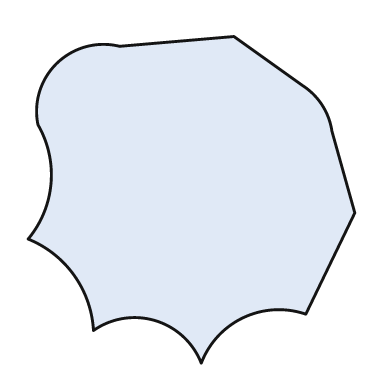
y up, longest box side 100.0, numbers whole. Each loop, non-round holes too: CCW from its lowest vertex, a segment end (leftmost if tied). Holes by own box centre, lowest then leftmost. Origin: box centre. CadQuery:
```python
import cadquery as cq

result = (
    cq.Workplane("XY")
    .moveTo(3.0, -50.0)
    .threePointArc((16.0, -36.0), (35.0, -35.0))
    .lineTo(50.0, -4.0)
    .lineTo(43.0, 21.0)
    .threePointArc((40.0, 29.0), (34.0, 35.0))
    .lineTo(13.0, 50.0)
    .lineTo(-22.0, 47.0)
    .threePointArc((-41.0, 42.0), (-47.0, 23.0))
    .threePointArc((-43.0, 5.0), (-50.0, -12.0))
    .threePointArc((-36.0, -23.0), (-30.0, -40.0))
    .threePointArc((-11.0, -37.0), (3.0, -50.0))
    .close()
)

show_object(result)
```